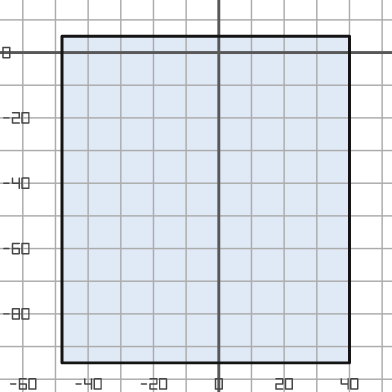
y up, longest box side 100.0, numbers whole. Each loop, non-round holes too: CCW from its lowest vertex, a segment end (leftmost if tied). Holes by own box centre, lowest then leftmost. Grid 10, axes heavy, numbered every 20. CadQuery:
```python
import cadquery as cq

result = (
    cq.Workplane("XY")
    .moveTo(-48.0, -95.0)
    .lineTo(40.0, -95.0)
    .lineTo(40.0, 5.0)
    .lineTo(-48.0, 5.0)
    .close()
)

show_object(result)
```